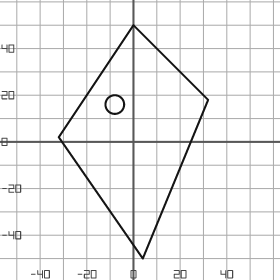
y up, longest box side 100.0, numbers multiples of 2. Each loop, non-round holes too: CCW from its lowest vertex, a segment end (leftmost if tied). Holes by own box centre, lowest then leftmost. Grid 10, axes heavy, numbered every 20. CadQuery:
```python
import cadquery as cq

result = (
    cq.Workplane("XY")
    .moveTo(4.0, -50.0)
    .lineTo(32.0, 18.0)
    .lineTo(0.0, 50.0)
    .lineTo(-32.0, 2.0)
    .close()
    .moveTo(-8.0, 16.0)
    .circle(4.0)
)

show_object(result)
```